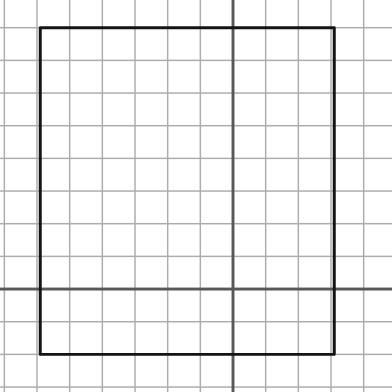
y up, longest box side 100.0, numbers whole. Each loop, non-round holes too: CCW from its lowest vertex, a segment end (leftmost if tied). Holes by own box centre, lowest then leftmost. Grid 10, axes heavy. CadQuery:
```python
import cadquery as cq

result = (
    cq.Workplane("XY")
    .moveTo(-59.0, -20.0)
    .lineTo(31.0, -20.0)
    .lineTo(31.0, 80.0)
    .lineTo(-59.0, 80.0)
    .close()
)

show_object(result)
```